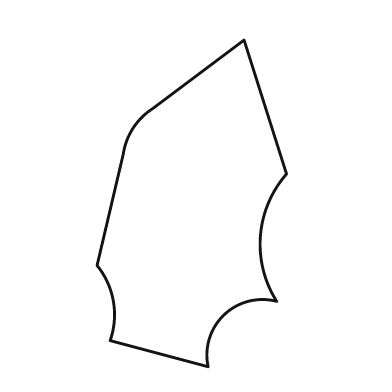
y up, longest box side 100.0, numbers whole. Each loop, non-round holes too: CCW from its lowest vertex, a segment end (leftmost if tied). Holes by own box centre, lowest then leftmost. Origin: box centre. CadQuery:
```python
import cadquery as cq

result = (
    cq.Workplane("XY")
    .moveTo(5.0, -50.0)
    .threePointArc((10.0, -34.0), (26.0, -30.0))
    .threePointArc((21.0, -10.0), (29.0, 9.0))
    .lineTo(16.0, 50.0)
    .lineTo(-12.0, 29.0)
    .threePointArc((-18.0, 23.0), (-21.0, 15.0))
    .lineTo(-29.0, -19.0)
    .threePointArc((-24.0, -30.0), (-25.0, -42.0))
    .close()
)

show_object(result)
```